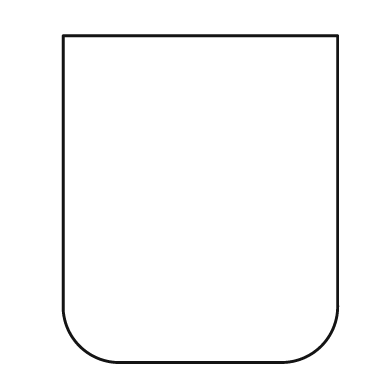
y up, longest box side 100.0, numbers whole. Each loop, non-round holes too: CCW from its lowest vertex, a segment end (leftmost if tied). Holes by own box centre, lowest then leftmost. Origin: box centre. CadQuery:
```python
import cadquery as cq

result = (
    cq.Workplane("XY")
    .moveTo(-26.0, -50.0)
    .lineTo(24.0, -50.0)
    .threePointArc((37.0, -45.0), (42.0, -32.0))
    .lineTo(42.0, 50.0)
    .lineTo(-42.0, 50.0)
    .lineTo(-42.0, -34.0)
    .threePointArc((-37.0, -45.0), (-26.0, -50.0))
    .close()
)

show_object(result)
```